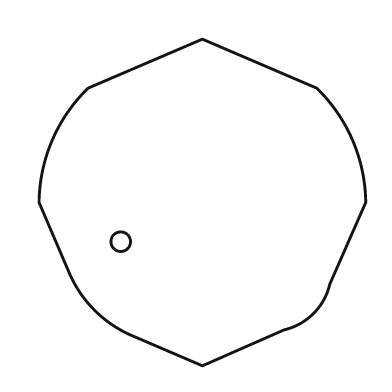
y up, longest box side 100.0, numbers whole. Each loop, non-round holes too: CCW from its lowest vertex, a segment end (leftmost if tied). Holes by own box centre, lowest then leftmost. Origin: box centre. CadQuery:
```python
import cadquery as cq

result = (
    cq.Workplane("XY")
    .moveTo(0.0, -50.0)
    .lineTo(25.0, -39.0)
    .threePointArc((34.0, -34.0), (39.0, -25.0))
    .lineTo(50.0, 0.0)
    .threePointArc((46.0, 19.0), (35.0, 35.0))
    .lineTo(0.0, 50.0)
    .lineTo(-35.0, 35.0)
    .threePointArc((-46.0, 19.0), (-50.0, 0.0))
    .lineTo(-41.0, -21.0)
    .threePointArc((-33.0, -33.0), (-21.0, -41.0))
    .close()
    .moveTo(-25.0, -12.0)
    .circle(3.0)
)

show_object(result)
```